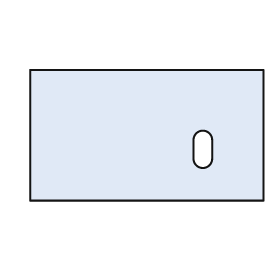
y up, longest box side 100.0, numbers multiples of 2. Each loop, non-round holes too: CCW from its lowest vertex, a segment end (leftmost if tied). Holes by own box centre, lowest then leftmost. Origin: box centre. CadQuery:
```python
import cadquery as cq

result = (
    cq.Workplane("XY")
    .moveTo(-50.0, -28.0)
    .lineTo(50.0, -28.0)
    .lineTo(50.0, 28.0)
    .lineTo(-50.0, 28.0)
    .close()
    .moveTo(20.0, -10.0)
    .threePointArc((24.0, -14.0), (28.0, -10.0))
    .lineTo(28.0, -2.0)
    .threePointArc((24.0, 2.0), (20.0, -2.0))
    .close()
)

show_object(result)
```